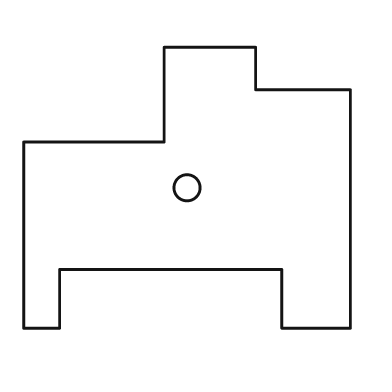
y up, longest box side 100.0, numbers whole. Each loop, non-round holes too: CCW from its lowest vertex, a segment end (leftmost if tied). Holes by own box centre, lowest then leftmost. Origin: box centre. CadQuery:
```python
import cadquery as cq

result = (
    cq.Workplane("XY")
    .moveTo(-50.0, -43.0)
    .lineTo(-39.0, -43.0)
    .lineTo(-39.0, -25.0)
    .lineTo(29.0, -25.0)
    .lineTo(29.0, -43.0)
    .lineTo(50.0, -43.0)
    .lineTo(50.0, 30.0)
    .lineTo(21.0, 30.0)
    .lineTo(21.0, 43.0)
    .lineTo(-7.0, 43.0)
    .lineTo(-7.0, 14.0)
    .lineTo(-50.0, 14.0)
    .close()
    .moveTo(0.0, 0.0)
    .circle(4.0)
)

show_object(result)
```